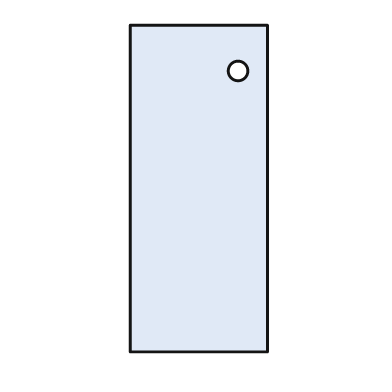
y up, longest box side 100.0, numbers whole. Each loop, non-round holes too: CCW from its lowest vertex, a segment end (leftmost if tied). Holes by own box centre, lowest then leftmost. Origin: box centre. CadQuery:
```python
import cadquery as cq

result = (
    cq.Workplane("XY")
    .moveTo(-21.0, -50.0)
    .lineTo(21.0, -50.0)
    .lineTo(21.0, 50.0)
    .lineTo(-21.0, 50.0)
    .close()
    .moveTo(12.0, 36.0)
    .circle(3.0)
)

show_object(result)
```